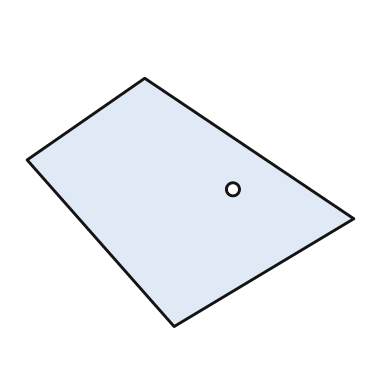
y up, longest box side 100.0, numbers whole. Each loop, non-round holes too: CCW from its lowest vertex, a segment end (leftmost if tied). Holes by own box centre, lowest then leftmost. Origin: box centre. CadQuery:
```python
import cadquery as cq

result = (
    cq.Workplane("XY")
    .moveTo(-5.0, -38.0)
    .lineTo(50.0, -5.0)
    .lineTo(-14.0, 38.0)
    .lineTo(-50.0, 13.0)
    .close()
    .moveTo(13.0, 4.0)
    .circle(2.0)
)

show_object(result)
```